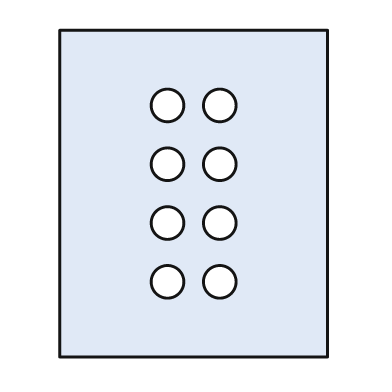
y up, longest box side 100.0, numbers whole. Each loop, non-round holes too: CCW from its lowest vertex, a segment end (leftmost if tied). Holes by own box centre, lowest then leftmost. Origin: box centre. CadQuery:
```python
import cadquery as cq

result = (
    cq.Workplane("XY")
    .moveTo(-41.0, -50.0)
    .lineTo(41.0, -50.0)
    .lineTo(41.0, 50.0)
    .lineTo(-41.0, 50.0)
    .close()
    .moveTo(-8.0, -27.0)
    .circle(5.0)
    .moveTo(8.0, -27.0)
    .circle(5.0)
    .moveTo(-8.0, -9.0)
    .circle(5.0)
    .moveTo(8.0, -9.0)
    .circle(5.0)
    .moveTo(-8.0, 9.0)
    .circle(5.0)
    .moveTo(8.0, 9.0)
    .circle(5.0)
    .moveTo(-8.0, 27.0)
    .circle(5.0)
    .moveTo(8.0, 27.0)
    .circle(5.0)
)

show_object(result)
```